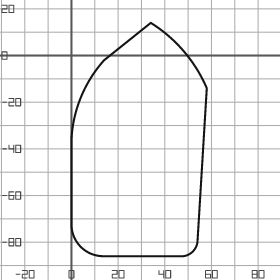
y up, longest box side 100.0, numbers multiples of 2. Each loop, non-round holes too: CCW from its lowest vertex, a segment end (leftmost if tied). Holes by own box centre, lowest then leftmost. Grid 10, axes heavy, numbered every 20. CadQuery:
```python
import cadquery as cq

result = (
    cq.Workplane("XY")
    .moveTo(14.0, -86.0)
    .lineTo(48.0, -86.0)
    .threePointArc((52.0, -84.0), (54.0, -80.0))
    .lineTo(58.0, -14.0)
    .threePointArc((48.0, 2.0), (34.0, 14.0))
    .lineTo(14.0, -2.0)
    .threePointArc((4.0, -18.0), (0.0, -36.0))
    .lineTo(0.0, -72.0)
    .threePointArc((4.0, -82.0), (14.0, -86.0))
    .close()
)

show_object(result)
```